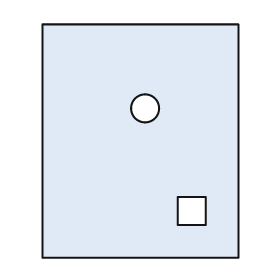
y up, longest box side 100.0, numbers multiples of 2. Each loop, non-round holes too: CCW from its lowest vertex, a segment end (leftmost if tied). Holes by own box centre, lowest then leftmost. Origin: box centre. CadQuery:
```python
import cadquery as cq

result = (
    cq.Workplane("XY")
    .moveTo(-42.0, -50.0)
    .lineTo(42.0, -50.0)
    .lineTo(42.0, 50.0)
    .lineTo(-42.0, 50.0)
    .close()
    .moveTo(16.0, -36.0)
    .lineTo(28.0, -36.0)
    .lineTo(28.0, -24.0)
    .lineTo(16.0, -24.0)
    .close()
    .moveTo(2.0, 14.0)
    .circle(6.0)
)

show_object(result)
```